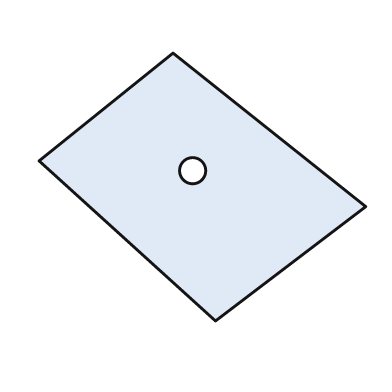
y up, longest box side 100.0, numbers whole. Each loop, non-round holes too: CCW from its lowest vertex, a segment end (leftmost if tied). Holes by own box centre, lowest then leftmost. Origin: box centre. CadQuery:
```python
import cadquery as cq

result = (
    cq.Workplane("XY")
    .moveTo(4.0, -41.0)
    .lineTo(50.0, -6.0)
    .lineTo(-9.0, 41.0)
    .lineTo(-50.0, 8.0)
    .close()
    .moveTo(-3.0, 5.0)
    .circle(4.0)
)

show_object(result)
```